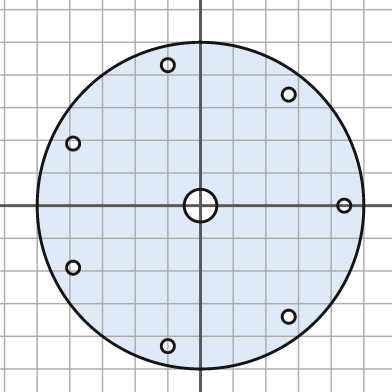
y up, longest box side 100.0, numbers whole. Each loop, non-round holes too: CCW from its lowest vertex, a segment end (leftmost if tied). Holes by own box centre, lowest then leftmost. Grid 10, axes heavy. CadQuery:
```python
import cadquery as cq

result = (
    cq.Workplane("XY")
    .moveTo(0.0, 0.0)
    .circle(50.0)
    .moveTo(-10.0, -43.0)
    .circle(2.0)
    .moveTo(27.0, -34.0)
    .circle(2.0)
    .moveTo(-39.0, -19.0)
    .circle(2.0)
    .moveTo(0.0, 0.0)
    .circle(5.0)
    .moveTo(44.0, 0.0)
    .circle(2.0)
    .moveTo(-39.0, 19.0)
    .circle(2.0)
    .moveTo(27.0, 34.0)
    .circle(2.0)
    .moveTo(-10.0, 43.0)
    .circle(2.0)
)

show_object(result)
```